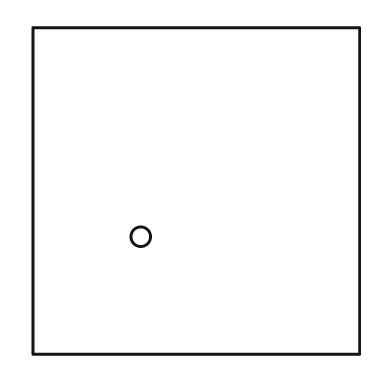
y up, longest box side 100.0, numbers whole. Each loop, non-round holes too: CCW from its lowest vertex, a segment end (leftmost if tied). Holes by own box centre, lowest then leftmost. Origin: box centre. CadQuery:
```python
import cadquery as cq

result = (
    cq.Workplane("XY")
    .moveTo(-50.0, -50.0)
    .lineTo(50.0, -50.0)
    .lineTo(50.0, 50.0)
    .lineTo(-50.0, 50.0)
    .close()
    .moveTo(-17.0, -14.0)
    .circle(3.0)
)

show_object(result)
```